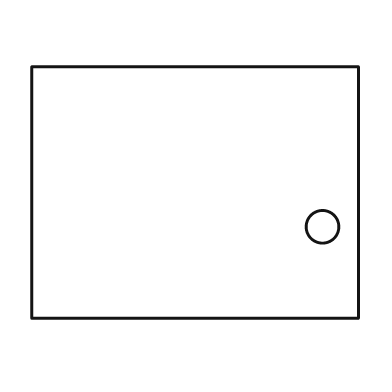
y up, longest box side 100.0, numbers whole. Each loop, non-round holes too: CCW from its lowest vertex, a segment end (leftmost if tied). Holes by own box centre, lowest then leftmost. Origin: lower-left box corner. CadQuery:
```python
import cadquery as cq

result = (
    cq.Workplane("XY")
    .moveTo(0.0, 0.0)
    .lineTo(100.0, 0.0)
    .lineTo(100.0, 77.0)
    .lineTo(0.0, 77.0)
    .close()
    .moveTo(89.0, 28.0)
    .circle(5.0)
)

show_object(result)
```